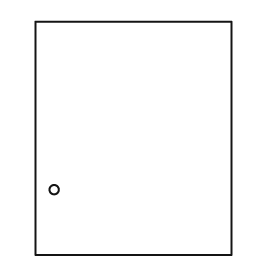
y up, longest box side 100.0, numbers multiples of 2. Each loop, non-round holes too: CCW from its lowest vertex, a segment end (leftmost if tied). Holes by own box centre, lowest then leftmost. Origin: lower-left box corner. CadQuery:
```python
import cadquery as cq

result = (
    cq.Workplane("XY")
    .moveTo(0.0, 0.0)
    .lineTo(84.0, 0.0)
    .lineTo(84.0, 100.0)
    .lineTo(0.0, 100.0)
    .close()
    .moveTo(8.0, 28.0)
    .circle(2.0)
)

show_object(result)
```